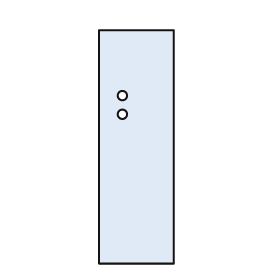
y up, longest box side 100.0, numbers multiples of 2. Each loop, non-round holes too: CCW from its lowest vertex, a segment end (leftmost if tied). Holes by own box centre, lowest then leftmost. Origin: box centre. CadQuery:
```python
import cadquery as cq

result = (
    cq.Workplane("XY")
    .moveTo(-16.0, -50.0)
    .lineTo(16.0, -50.0)
    .lineTo(16.0, 50.0)
    .lineTo(-16.0, 50.0)
    .close()
    .moveTo(-6.0, 14.0)
    .circle(2.0)
    .moveTo(-6.0, 22.0)
    .circle(2.0)
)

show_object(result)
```